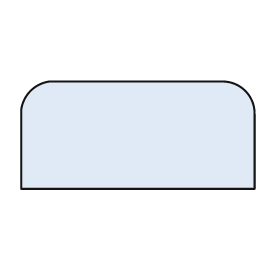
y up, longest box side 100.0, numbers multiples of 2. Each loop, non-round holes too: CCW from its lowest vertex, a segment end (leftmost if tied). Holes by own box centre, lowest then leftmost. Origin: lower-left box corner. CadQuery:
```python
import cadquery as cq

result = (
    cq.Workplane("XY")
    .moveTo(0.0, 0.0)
    .lineTo(100.0, 0.0)
    .lineTo(100.0, 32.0)
    .threePointArc((96.0, 42.0), (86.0, 46.0))
    .lineTo(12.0, 46.0)
    .threePointArc((4.0, 42.0), (0.0, 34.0))
    .close()
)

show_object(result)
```